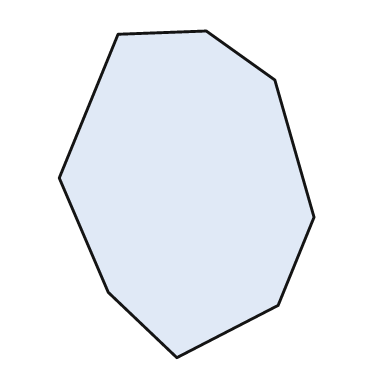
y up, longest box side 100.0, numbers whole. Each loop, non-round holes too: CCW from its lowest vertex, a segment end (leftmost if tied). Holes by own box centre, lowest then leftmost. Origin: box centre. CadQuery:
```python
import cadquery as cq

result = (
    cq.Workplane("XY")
    .moveTo(-3.0, -50.0)
    .lineTo(28.0, -34.0)
    .lineTo(39.0, -7.0)
    .lineTo(27.0, 35.0)
    .lineTo(6.0, 50.0)
    .lineTo(-21.0, 49.0)
    .lineTo(-39.0, 5.0)
    .lineTo(-24.0, -30.0)
    .close()
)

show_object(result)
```